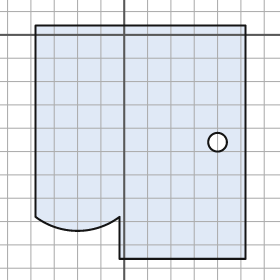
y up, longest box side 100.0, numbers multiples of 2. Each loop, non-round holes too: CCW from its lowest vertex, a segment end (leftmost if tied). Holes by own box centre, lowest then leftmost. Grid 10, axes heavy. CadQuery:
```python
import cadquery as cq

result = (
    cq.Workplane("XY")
    .moveTo(-2.0, -96.0)
    .lineTo(52.0, -96.0)
    .lineTo(52.0, 4.0)
    .lineTo(-38.0, 4.0)
    .lineTo(-38.0, -78.0)
    .threePointArc((-20.0, -84.0), (-2.0, -78.0))
    .close()
    .moveTo(40.0, -46.0)
    .circle(4.0)
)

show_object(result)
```